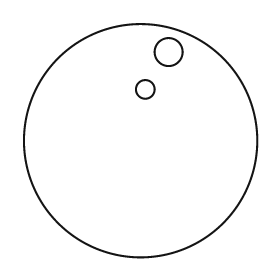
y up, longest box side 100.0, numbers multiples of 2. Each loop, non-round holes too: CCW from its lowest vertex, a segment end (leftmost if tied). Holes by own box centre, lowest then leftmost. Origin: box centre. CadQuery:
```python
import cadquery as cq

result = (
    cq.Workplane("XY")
    .moveTo(0.0, 0.0)
    .circle(50.0)
    .moveTo(2.0, 22.0)
    .circle(4.0)
    .moveTo(12.0, 38.0)
    .circle(6.0)
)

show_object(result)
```